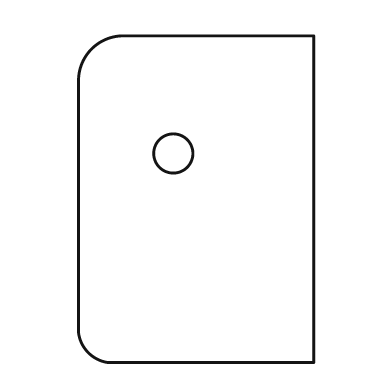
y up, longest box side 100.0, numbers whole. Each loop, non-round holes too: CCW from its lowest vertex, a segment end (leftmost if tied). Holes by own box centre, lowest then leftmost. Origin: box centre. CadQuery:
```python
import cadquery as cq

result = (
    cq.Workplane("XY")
    .moveTo(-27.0, -50.0)
    .lineTo(36.0, -50.0)
    .lineTo(36.0, 50.0)
    .lineTo(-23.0, 50.0)
    .threePointArc((-32.0, 46.0), (-36.0, 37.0))
    .lineTo(-36.0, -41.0)
    .threePointArc((-33.0, -47.0), (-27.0, -50.0))
    .close()
    .moveTo(-7.0, 14.0)
    .circle(6.0)
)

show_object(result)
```